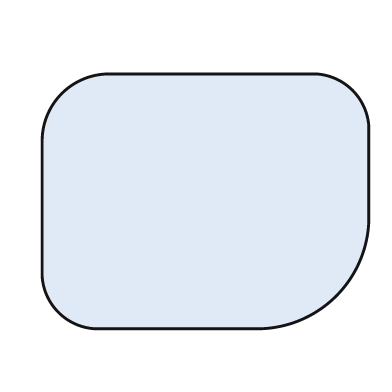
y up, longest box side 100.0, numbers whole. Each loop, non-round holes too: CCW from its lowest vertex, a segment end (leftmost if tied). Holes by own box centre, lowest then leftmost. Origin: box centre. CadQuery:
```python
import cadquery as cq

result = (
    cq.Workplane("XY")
    .moveTo(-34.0, -39.0)
    .lineTo(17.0, -39.0)
    .threePointArc((40.0, -29.0), (50.0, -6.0))
    .lineTo(50.0, 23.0)
    .threePointArc((45.0, 34.0), (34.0, 39.0))
    .lineTo(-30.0, 39.0)
    .threePointArc((-44.0, 33.0), (-50.0, 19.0))
    .lineTo(-50.0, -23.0)
    .threePointArc((-45.0, -34.0), (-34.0, -39.0))
    .close()
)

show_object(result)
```